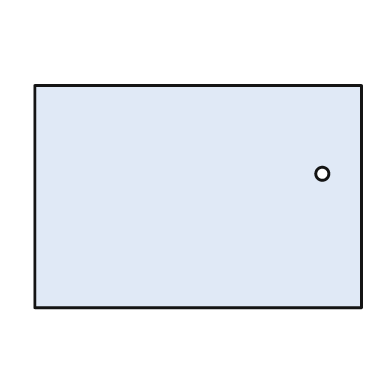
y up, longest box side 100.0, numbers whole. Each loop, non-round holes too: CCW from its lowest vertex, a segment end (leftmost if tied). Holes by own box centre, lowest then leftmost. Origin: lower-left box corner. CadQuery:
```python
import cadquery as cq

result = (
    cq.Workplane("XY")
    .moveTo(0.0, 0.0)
    .lineTo(100.0, 0.0)
    .lineTo(100.0, 68.0)
    .lineTo(0.0, 68.0)
    .close()
    .moveTo(88.0, 41.0)
    .circle(2.0)
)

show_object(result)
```